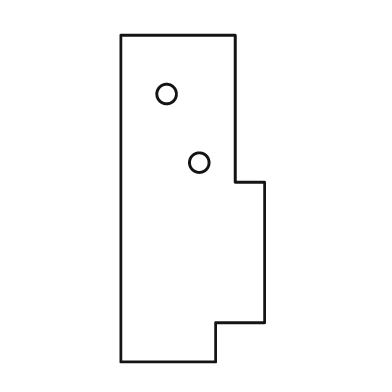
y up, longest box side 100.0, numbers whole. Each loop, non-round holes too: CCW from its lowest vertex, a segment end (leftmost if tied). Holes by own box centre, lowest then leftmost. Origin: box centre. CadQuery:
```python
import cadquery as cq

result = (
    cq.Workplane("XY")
    .moveTo(-22.0, -50.0)
    .lineTo(7.0, -50.0)
    .lineTo(7.0, -38.0)
    .lineTo(22.0, -38.0)
    .lineTo(22.0, 5.0)
    .lineTo(13.0, 5.0)
    .lineTo(13.0, 50.0)
    .lineTo(-22.0, 50.0)
    .close()
    .moveTo(2.0, 11.0)
    .circle(3.0)
    .moveTo(-8.0, 32.0)
    .circle(3.0)
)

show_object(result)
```